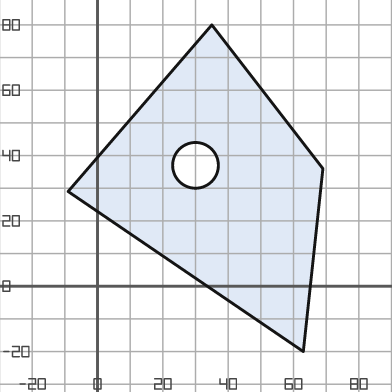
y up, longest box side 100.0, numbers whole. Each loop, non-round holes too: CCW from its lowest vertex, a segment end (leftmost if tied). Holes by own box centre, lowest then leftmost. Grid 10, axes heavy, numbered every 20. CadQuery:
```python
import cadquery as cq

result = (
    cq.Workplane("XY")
    .moveTo(63.0, -20.0)
    .lineTo(69.0, 36.0)
    .lineTo(35.0, 80.0)
    .lineTo(-9.0, 29.0)
    .close()
    .moveTo(30.0, 37.0)
    .circle(7.0)
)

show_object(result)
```